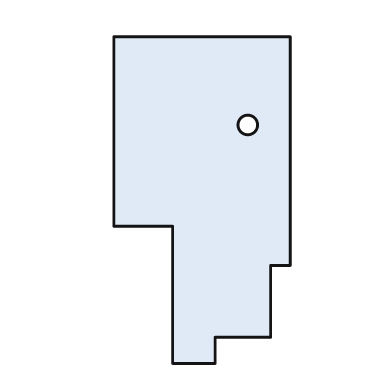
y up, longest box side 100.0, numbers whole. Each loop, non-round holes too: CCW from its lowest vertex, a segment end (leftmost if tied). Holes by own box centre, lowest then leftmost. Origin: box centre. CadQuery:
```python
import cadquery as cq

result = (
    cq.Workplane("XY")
    .moveTo(-9.0, -50.0)
    .lineTo(4.0, -50.0)
    .lineTo(4.0, -42.0)
    .lineTo(21.0, -42.0)
    .lineTo(21.0, -20.0)
    .lineTo(27.0, -20.0)
    .lineTo(27.0, 50.0)
    .lineTo(-27.0, 50.0)
    .lineTo(-27.0, -8.0)
    .lineTo(-9.0, -8.0)
    .close()
    .moveTo(14.0, 23.0)
    .circle(3.0)
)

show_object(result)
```